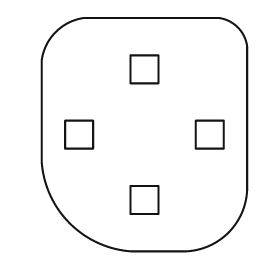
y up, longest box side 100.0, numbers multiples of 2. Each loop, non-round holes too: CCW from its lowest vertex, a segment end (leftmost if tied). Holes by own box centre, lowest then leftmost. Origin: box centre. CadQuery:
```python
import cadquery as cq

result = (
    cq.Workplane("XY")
    .moveTo(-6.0, -50.0)
    .lineTo(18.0, -50.0)
    .threePointArc((36.0, -42.0), (44.0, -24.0))
    .lineTo(44.0, 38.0)
    .threePointArc((40.0, 46.0), (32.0, 50.0))
    .lineTo(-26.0, 50.0)
    .threePointArc((-38.0, 44.0), (-44.0, 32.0))
    .lineTo(-44.0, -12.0)
    .threePointArc((-32.0, -38.0), (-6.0, -50.0))
    .close()
    .moveTo(-6.0, -34.0)
    .lineTo(6.0, -34.0)
    .lineTo(6.0, -22.0)
    .lineTo(-6.0, -22.0)
    .close()
    .moveTo(-34.0, -6.0)
    .lineTo(-22.0, -6.0)
    .lineTo(-22.0, 6.0)
    .lineTo(-34.0, 6.0)
    .close()
    .moveTo(22.0, -6.0)
    .lineTo(34.0, -6.0)
    .lineTo(34.0, 6.0)
    .lineTo(22.0, 6.0)
    .close()
    .moveTo(-6.0, 22.0)
    .lineTo(6.0, 22.0)
    .lineTo(6.0, 34.0)
    .lineTo(-6.0, 34.0)
    .close()
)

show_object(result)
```